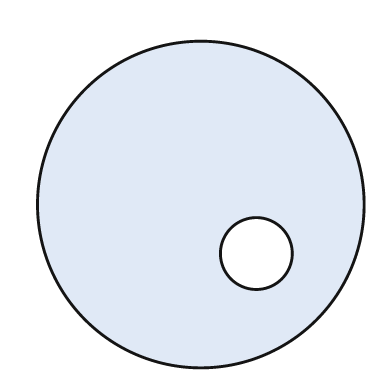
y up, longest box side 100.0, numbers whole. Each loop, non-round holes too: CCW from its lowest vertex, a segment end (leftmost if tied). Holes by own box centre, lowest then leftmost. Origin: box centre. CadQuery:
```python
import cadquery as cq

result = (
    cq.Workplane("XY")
    .moveTo(0.0, 0.0)
    .circle(50.0)
    .moveTo(17.0, -15.0)
    .circle(11.0)
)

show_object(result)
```